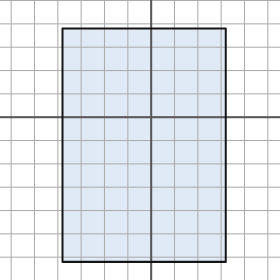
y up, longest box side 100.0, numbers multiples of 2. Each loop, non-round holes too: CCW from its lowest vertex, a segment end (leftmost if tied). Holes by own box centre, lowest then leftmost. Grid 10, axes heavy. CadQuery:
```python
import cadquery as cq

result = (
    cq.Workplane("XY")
    .moveTo(-38.0, -62.0)
    .lineTo(32.0, -62.0)
    .lineTo(32.0, 38.0)
    .lineTo(-38.0, 38.0)
    .close()
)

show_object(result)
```